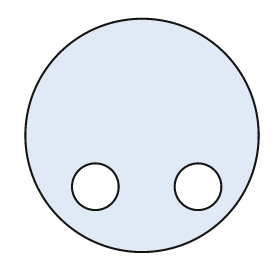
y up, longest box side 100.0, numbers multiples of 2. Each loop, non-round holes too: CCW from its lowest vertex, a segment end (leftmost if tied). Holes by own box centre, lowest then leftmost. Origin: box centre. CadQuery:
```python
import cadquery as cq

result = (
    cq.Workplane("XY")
    .moveTo(0.0, 0.0)
    .circle(50.0)
    .moveTo(-20.0, -22.0)
    .circle(10.0)
    .moveTo(24.0, -22.0)
    .circle(10.0)
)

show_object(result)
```